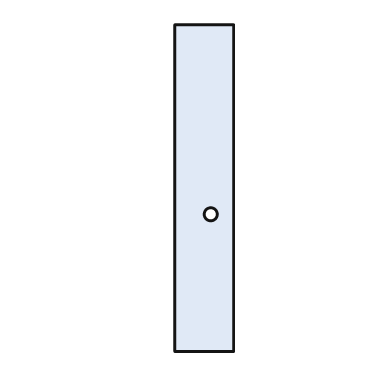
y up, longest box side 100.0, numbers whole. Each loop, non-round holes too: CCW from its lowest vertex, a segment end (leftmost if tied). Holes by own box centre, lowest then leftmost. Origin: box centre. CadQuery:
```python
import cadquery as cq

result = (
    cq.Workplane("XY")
    .moveTo(-9.0, -50.0)
    .lineTo(9.0, -50.0)
    .lineTo(9.0, 50.0)
    .lineTo(-9.0, 50.0)
    .close()
    .moveTo(2.0, -8.0)
    .circle(2.0)
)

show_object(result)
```